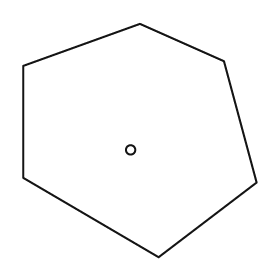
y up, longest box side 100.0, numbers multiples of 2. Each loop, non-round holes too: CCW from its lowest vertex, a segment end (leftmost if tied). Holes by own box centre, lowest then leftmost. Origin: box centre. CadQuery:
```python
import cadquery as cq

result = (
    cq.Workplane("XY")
    .moveTo(8.0, -50.0)
    .lineTo(50.0, -18.0)
    .lineTo(36.0, 34.0)
    .lineTo(0.0, 50.0)
    .lineTo(-50.0, 32.0)
    .lineTo(-50.0, -16.0)
    .close()
    .moveTo(-4.0, -4.0)
    .circle(2.0)
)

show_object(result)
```